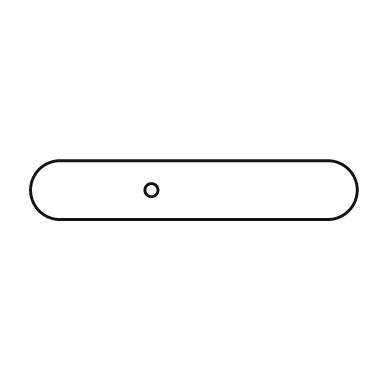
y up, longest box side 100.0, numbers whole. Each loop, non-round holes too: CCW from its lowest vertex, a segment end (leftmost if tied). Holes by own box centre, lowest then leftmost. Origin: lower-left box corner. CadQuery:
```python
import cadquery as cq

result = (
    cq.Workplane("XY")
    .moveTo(9.0, 0.0)
    .lineTo(91.0, 0.0)
    .threePointArc((100.0, 9.0), (91.0, 18.0))
    .lineTo(9.0, 18.0)
    .threePointArc((0.0, 9.0), (9.0, 0.0))
    .close()
    .moveTo(37.0, 9.0)
    .circle(2.0)
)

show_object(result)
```